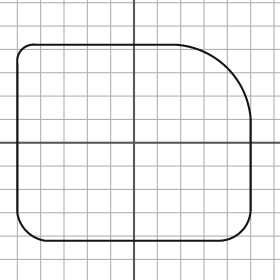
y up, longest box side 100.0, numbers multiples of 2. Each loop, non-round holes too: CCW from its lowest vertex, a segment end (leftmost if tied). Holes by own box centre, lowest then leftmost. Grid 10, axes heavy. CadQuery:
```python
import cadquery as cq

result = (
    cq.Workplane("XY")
    .moveTo(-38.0, -42.0)
    .lineTo(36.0, -42.0)
    .threePointArc((46.0, -38.0), (50.0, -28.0))
    .lineTo(50.0, 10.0)
    .threePointArc((40.0, 32.0), (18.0, 42.0))
    .lineTo(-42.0, 42.0)
    .threePointArc((-48.0, 40.0), (-50.0, 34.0))
    .lineTo(-50.0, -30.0)
    .threePointArc((-46.0, -38.0), (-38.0, -42.0))
    .close()
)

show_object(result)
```